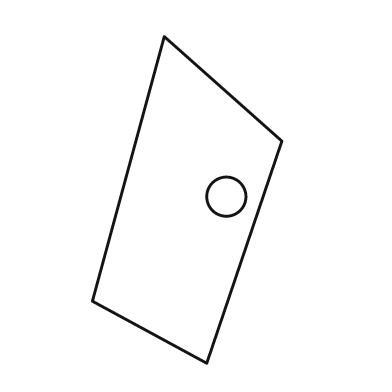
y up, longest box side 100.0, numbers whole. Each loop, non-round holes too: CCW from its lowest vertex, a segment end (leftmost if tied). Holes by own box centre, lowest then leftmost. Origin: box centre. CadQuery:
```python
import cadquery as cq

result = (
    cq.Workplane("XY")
    .moveTo(6.0, -50.0)
    .lineTo(29.0, 18.0)
    .lineTo(-7.0, 50.0)
    .lineTo(-29.0, -31.0)
    .close()
    .moveTo(12.0, 1.0)
    .circle(6.0)
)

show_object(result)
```